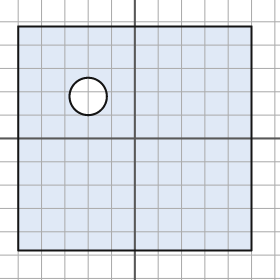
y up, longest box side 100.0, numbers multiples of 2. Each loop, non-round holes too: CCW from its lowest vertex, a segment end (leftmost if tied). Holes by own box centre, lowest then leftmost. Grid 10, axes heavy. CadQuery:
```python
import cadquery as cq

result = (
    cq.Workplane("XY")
    .moveTo(-50.0, -48.0)
    .lineTo(50.0, -48.0)
    .lineTo(50.0, 48.0)
    .lineTo(-50.0, 48.0)
    .close()
    .moveTo(-20.0, 18.0)
    .circle(8.0)
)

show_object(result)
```